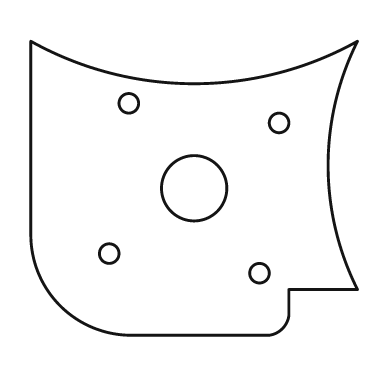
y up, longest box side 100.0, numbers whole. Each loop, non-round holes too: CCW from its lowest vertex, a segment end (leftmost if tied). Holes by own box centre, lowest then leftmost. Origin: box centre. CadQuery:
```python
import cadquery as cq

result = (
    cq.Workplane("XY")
    .moveTo(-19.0, -45.0)
    .lineTo(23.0, -45.0)
    .threePointArc((27.0, -43.0), (29.0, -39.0))
    .lineTo(29.0, -31.0)
    .lineTo(50.0, -31.0)
    .threePointArc((41.0, 7.0), (50.0, 45.0))
    .threePointArc((0.0, 32.0), (-50.0, 45.0))
    .lineTo(-50.0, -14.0)
    .threePointArc((-41.0, -36.0), (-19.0, -45.0))
    .close()
    .moveTo(20.0, -26.0)
    .circle(3.0)
    .moveTo(-26.0, -20.0)
    .circle(3.0)
    .moveTo(0.0, 0.0)
    .circle(10.0)
    .moveTo(26.0, 20.0)
    .circle(3.0)
    .moveTo(-20.0, 26.0)
    .circle(3.0)
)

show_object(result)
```